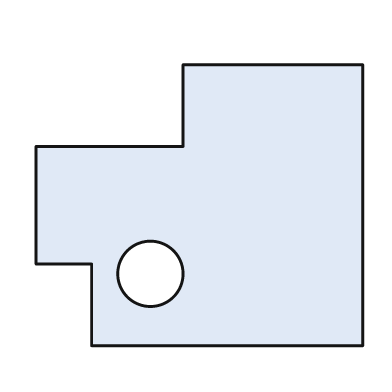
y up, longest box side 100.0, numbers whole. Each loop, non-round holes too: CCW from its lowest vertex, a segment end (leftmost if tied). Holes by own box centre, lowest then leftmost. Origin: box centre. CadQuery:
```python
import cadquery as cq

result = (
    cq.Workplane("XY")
    .moveTo(-33.0, -43.0)
    .lineTo(50.0, -43.0)
    .lineTo(50.0, 43.0)
    .lineTo(-5.0, 43.0)
    .lineTo(-5.0, 18.0)
    .lineTo(-50.0, 18.0)
    .lineTo(-50.0, -18.0)
    .lineTo(-33.0, -18.0)
    .close()
    .moveTo(-15.0, -21.0)
    .circle(10.0)
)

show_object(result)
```